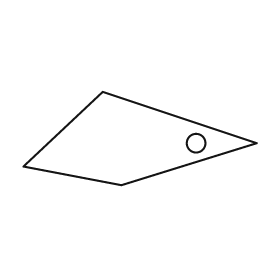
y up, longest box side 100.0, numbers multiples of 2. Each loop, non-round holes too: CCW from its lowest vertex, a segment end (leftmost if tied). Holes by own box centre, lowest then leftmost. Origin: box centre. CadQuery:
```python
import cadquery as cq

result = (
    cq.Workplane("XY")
    .moveTo(-8.0, -20.0)
    .lineTo(50.0, -2.0)
    .lineTo(-16.0, 20.0)
    .lineTo(-50.0, -12.0)
    .close()
    .moveTo(24.0, -2.0)
    .circle(4.0)
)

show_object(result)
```